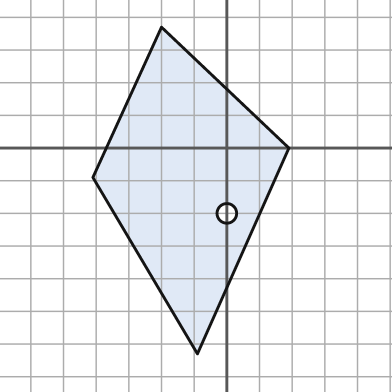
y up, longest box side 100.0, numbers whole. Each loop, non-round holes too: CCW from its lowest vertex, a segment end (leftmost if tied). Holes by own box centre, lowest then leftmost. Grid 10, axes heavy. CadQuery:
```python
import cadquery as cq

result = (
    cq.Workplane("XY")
    .moveTo(-9.0, -63.0)
    .lineTo(19.0, 0.0)
    .lineTo(-20.0, 37.0)
    .lineTo(-41.0, -9.0)
    .close()
    .moveTo(0.0, -20.0)
    .circle(3.0)
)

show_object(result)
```